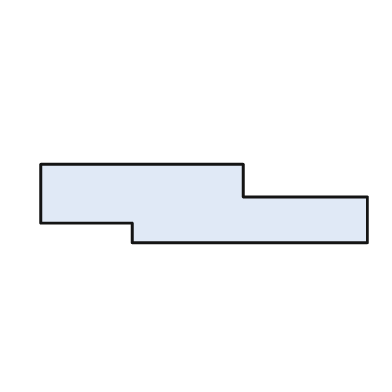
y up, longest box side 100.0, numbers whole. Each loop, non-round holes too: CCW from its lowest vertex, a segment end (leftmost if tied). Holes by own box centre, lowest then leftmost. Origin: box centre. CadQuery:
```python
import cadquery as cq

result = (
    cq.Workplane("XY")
    .moveTo(-22.0, -12.0)
    .lineTo(50.0, -12.0)
    .lineTo(50.0, 2.0)
    .lineTo(12.0, 2.0)
    .lineTo(12.0, 12.0)
    .lineTo(-50.0, 12.0)
    .lineTo(-50.0, -6.0)
    .lineTo(-22.0, -6.0)
    .close()
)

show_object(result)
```